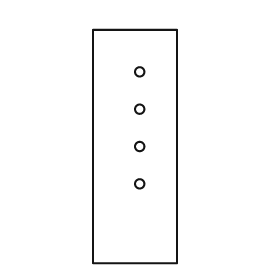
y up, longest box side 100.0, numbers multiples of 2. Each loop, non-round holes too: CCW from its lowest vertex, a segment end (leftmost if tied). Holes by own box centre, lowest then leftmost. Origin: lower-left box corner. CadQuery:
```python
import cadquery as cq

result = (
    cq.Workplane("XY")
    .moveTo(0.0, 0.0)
    .lineTo(36.0, 0.0)
    .lineTo(36.0, 100.0)
    .lineTo(0.0, 100.0)
    .close()
    .moveTo(20.0, 34.0)
    .circle(2.0)
    .moveTo(20.0, 50.0)
    .circle(2.0)
    .moveTo(20.0, 66.0)
    .circle(2.0)
    .moveTo(20.0, 82.0)
    .circle(2.0)
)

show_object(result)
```